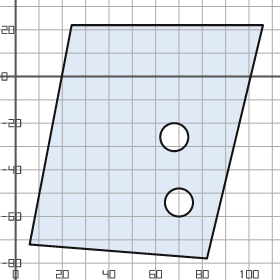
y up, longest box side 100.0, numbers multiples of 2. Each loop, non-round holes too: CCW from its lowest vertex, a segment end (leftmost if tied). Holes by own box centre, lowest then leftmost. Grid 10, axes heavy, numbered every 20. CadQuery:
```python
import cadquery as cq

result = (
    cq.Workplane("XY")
    .moveTo(82.0, -78.0)
    .lineTo(106.0, 22.0)
    .lineTo(24.0, 22.0)
    .lineTo(6.0, -72.0)
    .close()
    .moveTo(70.0, -54.0)
    .circle(6.0)
    .moveTo(68.0, -26.0)
    .circle(6.0)
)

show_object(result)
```